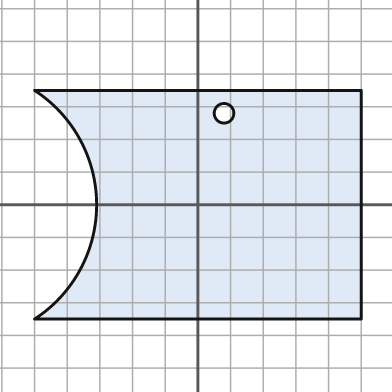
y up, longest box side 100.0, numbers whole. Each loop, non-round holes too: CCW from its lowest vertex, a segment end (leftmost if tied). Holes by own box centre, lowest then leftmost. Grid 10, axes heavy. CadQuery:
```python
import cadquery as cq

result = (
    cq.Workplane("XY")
    .moveTo(-50.0, -35.0)
    .lineTo(50.0, -35.0)
    .lineTo(50.0, 35.0)
    .lineTo(-50.0, 35.0)
    .threePointArc((-31.0, 0.0), (-50.0, -35.0))
    .close()
    .moveTo(8.0, 28.0)
    .circle(3.0)
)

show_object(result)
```